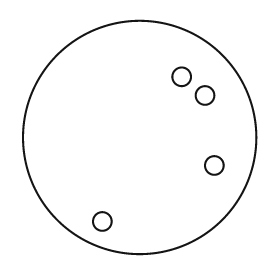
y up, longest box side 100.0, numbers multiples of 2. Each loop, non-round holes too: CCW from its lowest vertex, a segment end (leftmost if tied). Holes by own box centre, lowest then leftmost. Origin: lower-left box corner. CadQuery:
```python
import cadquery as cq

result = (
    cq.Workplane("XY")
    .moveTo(50.0, 50.0)
    .circle(50.0)
    .moveTo(34.0, 14.0)
    .circle(4.0)
    .moveTo(82.0, 38.0)
    .circle(4.0)
    .moveTo(78.0, 68.0)
    .circle(4.0)
    .moveTo(68.0, 76.0)
    .circle(4.0)
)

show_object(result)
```